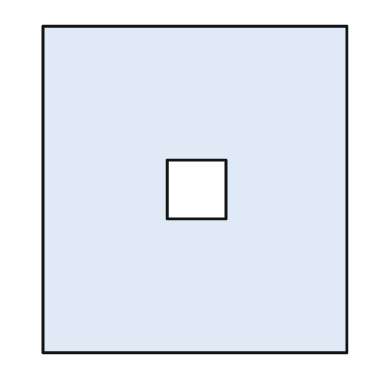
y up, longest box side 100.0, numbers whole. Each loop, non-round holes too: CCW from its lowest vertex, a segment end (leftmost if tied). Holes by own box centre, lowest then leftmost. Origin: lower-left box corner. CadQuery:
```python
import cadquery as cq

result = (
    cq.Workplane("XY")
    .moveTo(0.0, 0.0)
    .lineTo(93.0, 0.0)
    .lineTo(93.0, 100.0)
    .lineTo(0.0, 100.0)
    .close()
    .moveTo(38.0, 41.0)
    .lineTo(56.0, 41.0)
    .lineTo(56.0, 59.0)
    .lineTo(38.0, 59.0)
    .close()
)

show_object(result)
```